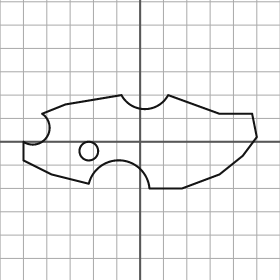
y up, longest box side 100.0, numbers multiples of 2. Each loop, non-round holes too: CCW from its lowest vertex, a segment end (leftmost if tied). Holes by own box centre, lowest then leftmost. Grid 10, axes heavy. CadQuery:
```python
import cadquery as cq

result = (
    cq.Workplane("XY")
    .moveTo(4.0, -20.0)
    .lineTo(18.0, -20.0)
    .lineTo(34.0, -14.0)
    .lineTo(44.0, -6.0)
    .lineTo(50.0, 2.0)
    .lineTo(48.0, 12.0)
    .lineTo(34.0, 12.0)
    .lineTo(12.0, 20.0)
    .threePointArc((2.0, 14.0), (-8.0, 20.0))
    .lineTo(-32.0, 16.0)
    .lineTo(-42.0, 12.0)
    .threePointArc((-40.0, 2.0), (-50.0, 0.0))
    .lineTo(-50.0, -8.0)
    .lineTo(-38.0, -14.0)
    .lineTo(-22.0, -18.0)
    .threePointArc((-8.0, -8.0), (4.0, -20.0))
    .close()
    .moveTo(-22.0, -4.0)
    .circle(4.0)
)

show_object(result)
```